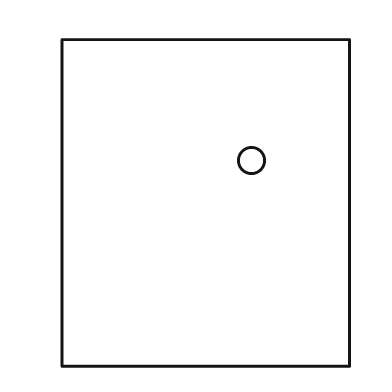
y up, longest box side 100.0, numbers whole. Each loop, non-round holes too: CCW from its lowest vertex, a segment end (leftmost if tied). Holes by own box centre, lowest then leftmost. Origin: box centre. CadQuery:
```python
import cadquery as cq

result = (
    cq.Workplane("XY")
    .moveTo(-44.0, -50.0)
    .lineTo(44.0, -50.0)
    .lineTo(44.0, 50.0)
    .lineTo(-44.0, 50.0)
    .close()
    .moveTo(14.0, 13.0)
    .circle(4.0)
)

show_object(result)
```